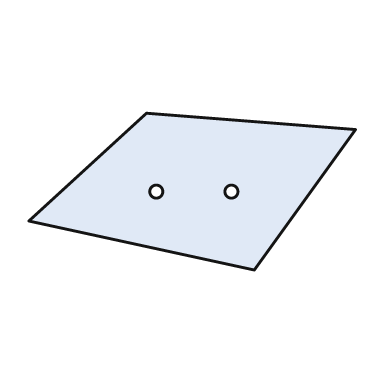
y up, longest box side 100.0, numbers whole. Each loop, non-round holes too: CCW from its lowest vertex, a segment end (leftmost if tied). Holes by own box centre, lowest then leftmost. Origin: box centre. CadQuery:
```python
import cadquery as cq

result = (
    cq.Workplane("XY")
    .moveTo(19.0, -24.0)
    .lineTo(50.0, 19.0)
    .lineTo(-14.0, 24.0)
    .lineTo(-50.0, -9.0)
    .close()
    .moveTo(-11.0, 0.0)
    .circle(2.0)
    .moveTo(12.0, 0.0)
    .circle(2.0)
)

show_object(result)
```